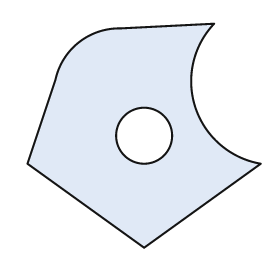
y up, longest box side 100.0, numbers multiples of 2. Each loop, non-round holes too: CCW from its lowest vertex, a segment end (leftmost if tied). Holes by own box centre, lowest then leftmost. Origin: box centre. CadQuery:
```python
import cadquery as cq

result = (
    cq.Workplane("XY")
    .moveTo(0.0, -48.0)
    .lineTo(50.0, -12.0)
    .threePointArc((22.0, 12.0), (30.0, 48.0))
    .lineTo(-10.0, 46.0)
    .threePointArc((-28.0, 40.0), (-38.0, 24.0))
    .lineTo(-50.0, -12.0)
    .close()
    .moveTo(0.0, 0.0)
    .circle(12.0)
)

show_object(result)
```